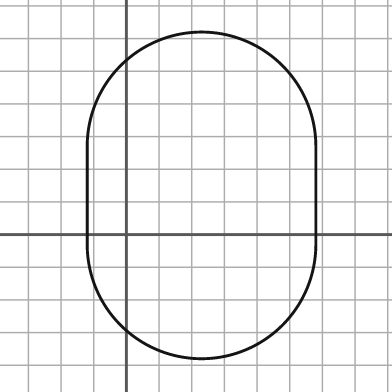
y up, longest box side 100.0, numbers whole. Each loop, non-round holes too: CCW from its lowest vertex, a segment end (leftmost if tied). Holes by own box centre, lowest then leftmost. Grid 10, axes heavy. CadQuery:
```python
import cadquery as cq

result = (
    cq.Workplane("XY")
    .moveTo(-12.0, -3.0)
    .threePointArc((23.0, -38.0), (58.0, -3.0))
    .lineTo(58.0, 27.0)
    .threePointArc((23.0, 62.0), (-12.0, 27.0))
    .close()
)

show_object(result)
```